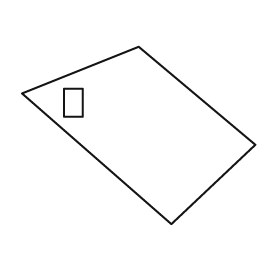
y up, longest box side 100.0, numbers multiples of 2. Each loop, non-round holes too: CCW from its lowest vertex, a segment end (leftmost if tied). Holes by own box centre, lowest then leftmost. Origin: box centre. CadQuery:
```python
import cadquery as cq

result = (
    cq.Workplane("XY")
    .moveTo(14.0, -38.0)
    .lineTo(50.0, -4.0)
    .lineTo(0.0, 38.0)
    .lineTo(-50.0, 18.0)
    .close()
    .moveTo(-32.0, 8.0)
    .lineTo(-24.0, 8.0)
    .lineTo(-24.0, 20.0)
    .lineTo(-32.0, 20.0)
    .close()
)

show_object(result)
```